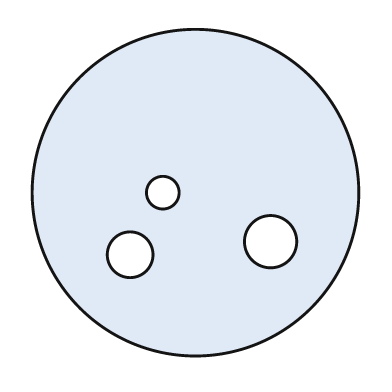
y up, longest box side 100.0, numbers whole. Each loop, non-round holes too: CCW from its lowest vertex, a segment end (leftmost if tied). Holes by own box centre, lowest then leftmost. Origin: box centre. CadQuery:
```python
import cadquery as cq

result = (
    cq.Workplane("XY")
    .moveTo(0.0, 0.0)
    .circle(50.0)
    .moveTo(-20.0, -19.0)
    .circle(7.0)
    .moveTo(23.0, -15.0)
    .circle(8.0)
    .moveTo(-10.0, 0.0)
    .circle(5.0)
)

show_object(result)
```